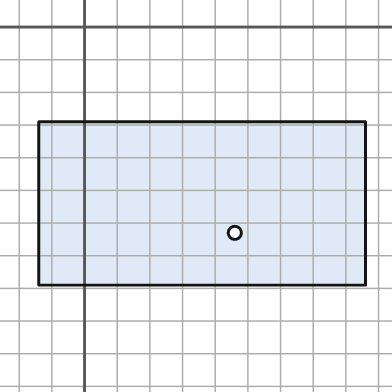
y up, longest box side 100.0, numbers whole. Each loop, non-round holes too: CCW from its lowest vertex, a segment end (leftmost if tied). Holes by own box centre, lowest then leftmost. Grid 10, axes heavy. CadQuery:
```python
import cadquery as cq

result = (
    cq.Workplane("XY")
    .moveTo(-14.0, -79.0)
    .lineTo(86.0, -79.0)
    .lineTo(86.0, -29.0)
    .lineTo(-14.0, -29.0)
    .close()
    .moveTo(46.0, -63.0)
    .circle(2.0)
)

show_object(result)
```